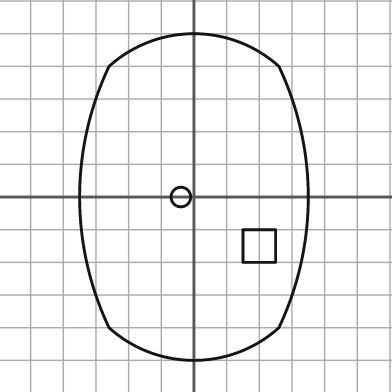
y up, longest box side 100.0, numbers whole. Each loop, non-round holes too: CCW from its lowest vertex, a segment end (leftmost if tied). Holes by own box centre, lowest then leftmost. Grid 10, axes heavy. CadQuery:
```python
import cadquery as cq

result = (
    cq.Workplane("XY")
    .moveTo(-26.0, -40.0)
    .threePointArc((0.0, -50.0), (26.0, -40.0))
    .threePointArc((35.0, 0.0), (26.0, 40.0))
    .threePointArc((0.0, 50.0), (-26.0, 40.0))
    .threePointArc((-35.0, 0.0), (-26.0, -40.0))
    .close()
    .moveTo(15.0, -20.0)
    .lineTo(25.0, -20.0)
    .lineTo(25.0, -10.0)
    .lineTo(15.0, -10.0)
    .close()
    .moveTo(-4.0, 0.0)
    .circle(3.0)
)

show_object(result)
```